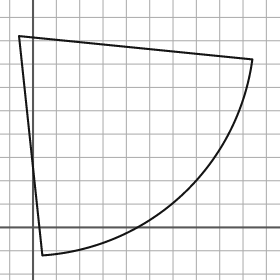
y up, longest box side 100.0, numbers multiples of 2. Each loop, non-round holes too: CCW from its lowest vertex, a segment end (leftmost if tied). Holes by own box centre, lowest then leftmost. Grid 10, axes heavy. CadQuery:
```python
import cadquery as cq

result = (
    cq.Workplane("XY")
    .moveTo(4.0, -12.0)
    .threePointArc((64.0, 14.0), (94.0, 72.0))
    .lineTo(-6.0, 82.0)
    .close()
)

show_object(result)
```